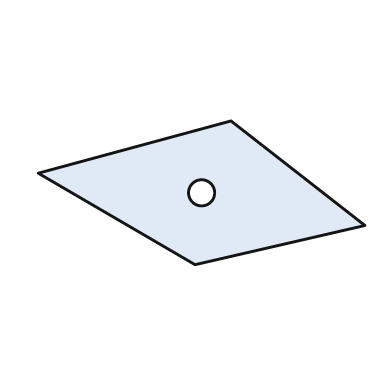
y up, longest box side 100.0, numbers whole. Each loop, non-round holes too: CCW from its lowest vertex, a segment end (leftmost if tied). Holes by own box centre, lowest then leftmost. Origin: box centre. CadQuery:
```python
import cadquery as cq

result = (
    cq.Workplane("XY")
    .moveTo(-2.0, -22.0)
    .lineTo(50.0, -10.0)
    .lineTo(9.0, 22.0)
    .lineTo(-50.0, 6.0)
    .close()
    .moveTo(0.0, 0.0)
    .circle(4.0)
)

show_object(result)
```